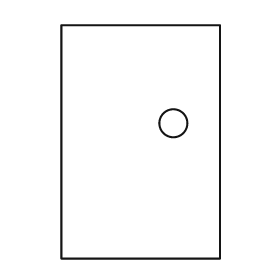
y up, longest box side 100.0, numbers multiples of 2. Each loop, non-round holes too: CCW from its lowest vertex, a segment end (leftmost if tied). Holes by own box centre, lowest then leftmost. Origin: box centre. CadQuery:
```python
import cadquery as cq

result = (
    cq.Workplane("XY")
    .moveTo(-34.0, -50.0)
    .lineTo(34.0, -50.0)
    .lineTo(34.0, 50.0)
    .lineTo(-34.0, 50.0)
    .close()
    .moveTo(14.0, 8.0)
    .circle(6.0)
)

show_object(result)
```